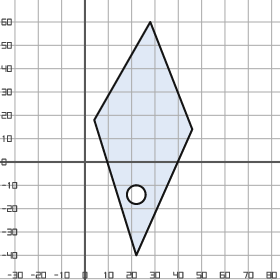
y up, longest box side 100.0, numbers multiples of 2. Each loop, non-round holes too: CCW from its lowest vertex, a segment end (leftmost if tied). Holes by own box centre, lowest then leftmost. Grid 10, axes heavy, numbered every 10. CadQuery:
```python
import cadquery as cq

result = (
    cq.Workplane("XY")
    .moveTo(22.0, -40.0)
    .lineTo(46.0, 14.0)
    .lineTo(28.0, 60.0)
    .lineTo(4.0, 18.0)
    .close()
    .moveTo(22.0, -14.0)
    .circle(4.0)
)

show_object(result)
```